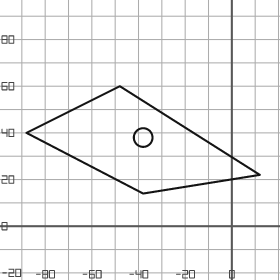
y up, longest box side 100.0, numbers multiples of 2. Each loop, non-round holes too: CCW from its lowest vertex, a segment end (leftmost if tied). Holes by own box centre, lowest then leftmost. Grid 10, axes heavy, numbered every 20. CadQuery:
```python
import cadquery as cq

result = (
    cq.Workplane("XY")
    .moveTo(-38.0, 14.0)
    .lineTo(12.0, 22.0)
    .lineTo(-48.0, 60.0)
    .lineTo(-88.0, 40.0)
    .close()
    .moveTo(-38.0, 38.0)
    .circle(4.0)
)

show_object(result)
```